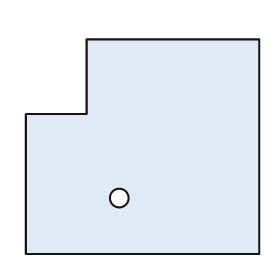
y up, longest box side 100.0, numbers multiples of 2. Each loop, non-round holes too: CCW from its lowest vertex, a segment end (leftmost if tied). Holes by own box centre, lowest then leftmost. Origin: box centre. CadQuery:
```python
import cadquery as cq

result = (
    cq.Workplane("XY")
    .moveTo(-50.0, -46.0)
    .lineTo(50.0, -46.0)
    .lineTo(50.0, 46.0)
    .lineTo(-24.0, 46.0)
    .lineTo(-24.0, 14.0)
    .lineTo(-50.0, 14.0)
    .close()
    .moveTo(-10.0, -22.0)
    .circle(4.0)
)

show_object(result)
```